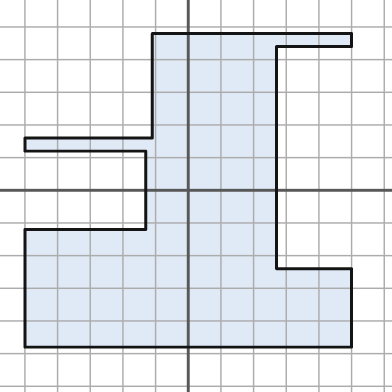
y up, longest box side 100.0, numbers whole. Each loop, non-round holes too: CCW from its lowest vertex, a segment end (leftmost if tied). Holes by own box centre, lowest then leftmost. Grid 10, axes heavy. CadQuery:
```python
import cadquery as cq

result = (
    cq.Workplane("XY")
    .moveTo(-50.0, -48.0)
    .lineTo(50.0, -48.0)
    .lineTo(50.0, -24.0)
    .lineTo(27.0, -24.0)
    .lineTo(27.0, 44.0)
    .lineTo(50.0, 44.0)
    .lineTo(50.0, 48.0)
    .lineTo(-11.0, 48.0)
    .lineTo(-11.0, 16.0)
    .lineTo(-50.0, 16.0)
    .lineTo(-50.0, 12.0)
    .lineTo(-13.0, 12.0)
    .lineTo(-13.0, -12.0)
    .lineTo(-50.0, -12.0)
    .close()
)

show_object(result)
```